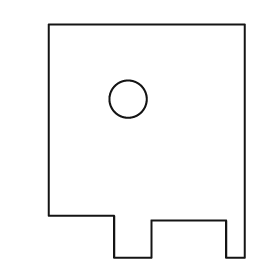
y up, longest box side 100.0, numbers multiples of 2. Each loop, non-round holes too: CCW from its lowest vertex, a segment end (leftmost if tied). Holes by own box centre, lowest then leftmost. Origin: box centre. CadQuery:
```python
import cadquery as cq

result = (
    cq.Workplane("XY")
    .moveTo(-14.0, -50.0)
    .lineTo(2.0, -50.0)
    .lineTo(2.0, -34.0)
    .lineTo(34.0, -34.0)
    .lineTo(34.0, -50.0)
    .lineTo(42.0, -50.0)
    .lineTo(42.0, 50.0)
    .lineTo(-42.0, 50.0)
    .lineTo(-42.0, -32.0)
    .lineTo(-14.0, -32.0)
    .close()
    .moveTo(-8.0, 18.0)
    .circle(8.0)
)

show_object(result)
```